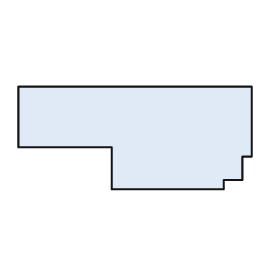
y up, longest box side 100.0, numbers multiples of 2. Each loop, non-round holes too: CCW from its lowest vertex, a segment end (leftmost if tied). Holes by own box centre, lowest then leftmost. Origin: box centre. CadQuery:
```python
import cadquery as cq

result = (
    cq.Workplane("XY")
    .moveTo(-10.0, -22.0)
    .lineTo(38.0, -22.0)
    .lineTo(38.0, -18.0)
    .lineTo(46.0, -18.0)
    .lineTo(46.0, -8.0)
    .lineTo(50.0, -8.0)
    .lineTo(50.0, 22.0)
    .lineTo(-50.0, 22.0)
    .lineTo(-50.0, -4.0)
    .lineTo(-10.0, -4.0)
    .close()
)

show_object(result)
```